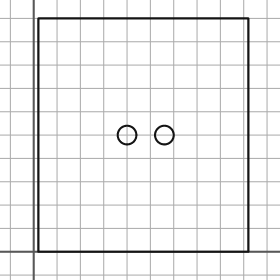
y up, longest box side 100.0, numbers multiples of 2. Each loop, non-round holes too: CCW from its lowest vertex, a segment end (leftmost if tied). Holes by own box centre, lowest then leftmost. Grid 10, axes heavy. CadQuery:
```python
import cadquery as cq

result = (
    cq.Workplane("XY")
    .moveTo(2.0, 0.0)
    .lineTo(92.0, 0.0)
    .lineTo(92.0, 100.0)
    .lineTo(2.0, 100.0)
    .close()
    .moveTo(40.0, 50.0)
    .circle(4.0)
    .moveTo(56.0, 50.0)
    .circle(4.0)
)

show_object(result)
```